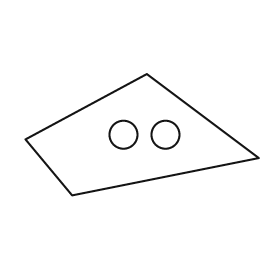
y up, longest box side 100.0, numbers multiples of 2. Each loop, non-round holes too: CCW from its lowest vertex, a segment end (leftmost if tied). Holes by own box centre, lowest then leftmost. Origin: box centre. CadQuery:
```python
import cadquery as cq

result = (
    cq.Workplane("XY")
    .moveTo(-30.0, -26.0)
    .lineTo(50.0, -10.0)
    .lineTo(2.0, 26.0)
    .lineTo(-50.0, -2.0)
    .close()
    .moveTo(-8.0, 0.0)
    .circle(6.0)
    .moveTo(10.0, 0.0)
    .circle(6.0)
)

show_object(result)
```